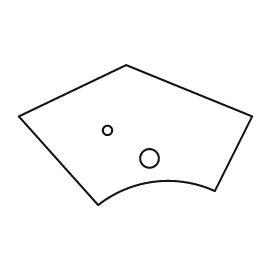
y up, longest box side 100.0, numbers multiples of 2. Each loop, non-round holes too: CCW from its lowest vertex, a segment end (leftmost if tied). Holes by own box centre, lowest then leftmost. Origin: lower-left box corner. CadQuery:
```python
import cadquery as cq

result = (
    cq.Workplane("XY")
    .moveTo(34.0, 0.0)
    .threePointArc((58.0, 10.0), (84.0, 6.0))
    .lineTo(100.0, 38.0)
    .lineTo(46.0, 60.0)
    .lineTo(0.0, 38.0)
    .close()
    .moveTo(56.0, 20.0)
    .circle(4.0)
    .moveTo(38.0, 32.0)
    .circle(2.0)
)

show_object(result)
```